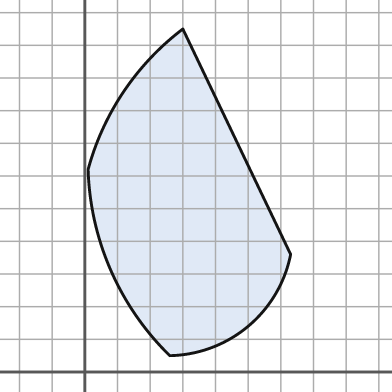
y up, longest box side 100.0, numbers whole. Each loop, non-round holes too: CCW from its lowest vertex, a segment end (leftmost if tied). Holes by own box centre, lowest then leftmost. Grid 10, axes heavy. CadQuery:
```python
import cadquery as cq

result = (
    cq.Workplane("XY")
    .moveTo(26.0, 5.0)
    .threePointArc((50.0, 14.0), (63.0, 36.0))
    .lineTo(30.0, 105.0)
    .threePointArc((12.0, 86.0), (1.0, 62.0))
    .threePointArc((8.0, 31.0), (26.0, 5.0))
    .close()
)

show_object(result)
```